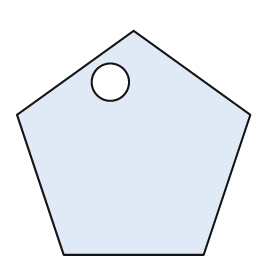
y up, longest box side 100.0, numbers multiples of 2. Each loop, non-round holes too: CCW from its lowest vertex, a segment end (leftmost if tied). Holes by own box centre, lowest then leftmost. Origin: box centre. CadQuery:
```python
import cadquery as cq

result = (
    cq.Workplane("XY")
    .moveTo(-30.0, -48.0)
    .lineTo(30.0, -48.0)
    .lineTo(50.0, 12.0)
    .lineTo(0.0, 48.0)
    .lineTo(-50.0, 12.0)
    .close()
    .moveTo(-10.0, 26.0)
    .circle(8.0)
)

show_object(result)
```